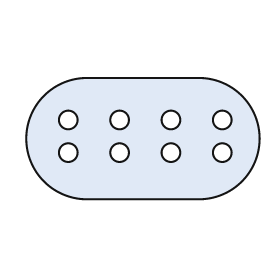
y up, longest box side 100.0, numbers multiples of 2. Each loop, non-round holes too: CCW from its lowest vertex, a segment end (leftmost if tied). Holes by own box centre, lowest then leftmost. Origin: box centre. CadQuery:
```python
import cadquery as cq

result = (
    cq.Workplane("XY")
    .moveTo(-24.0, -26.0)
    .lineTo(24.0, -26.0)
    .threePointArc((50.0, 0.0), (24.0, 26.0))
    .lineTo(-24.0, 26.0)
    .threePointArc((-50.0, 0.0), (-24.0, -26.0))
    .close()
    .moveTo(-32.0, -6.0)
    .circle(4.0)
    .moveTo(-10.0, -6.0)
    .circle(4.0)
    .moveTo(12.0, -6.0)
    .circle(4.0)
    .moveTo(34.0, -6.0)
    .circle(4.0)
    .moveTo(-32.0, 8.0)
    .circle(4.0)
    .moveTo(-10.0, 8.0)
    .circle(4.0)
    .moveTo(12.0, 8.0)
    .circle(4.0)
    .moveTo(34.0, 8.0)
    .circle(4.0)
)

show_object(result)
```